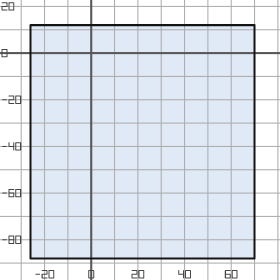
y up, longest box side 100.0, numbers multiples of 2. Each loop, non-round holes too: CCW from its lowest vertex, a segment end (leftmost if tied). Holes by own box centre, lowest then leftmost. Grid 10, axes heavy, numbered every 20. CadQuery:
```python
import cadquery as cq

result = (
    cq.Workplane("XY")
    .moveTo(-26.0, -88.0)
    .lineTo(70.0, -88.0)
    .lineTo(70.0, 12.0)
    .lineTo(-26.0, 12.0)
    .close()
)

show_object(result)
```